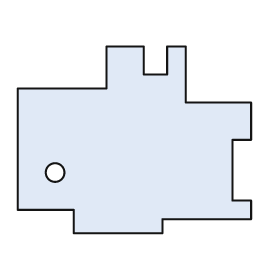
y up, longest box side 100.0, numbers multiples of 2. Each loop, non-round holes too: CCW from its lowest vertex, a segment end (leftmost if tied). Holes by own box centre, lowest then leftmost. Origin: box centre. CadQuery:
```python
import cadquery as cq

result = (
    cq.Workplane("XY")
    .moveTo(-26.0, -40.0)
    .lineTo(12.0, -40.0)
    .lineTo(12.0, -34.0)
    .lineTo(50.0, -34.0)
    .lineTo(50.0, -26.0)
    .lineTo(42.0, -26.0)
    .lineTo(42.0, 0.0)
    .lineTo(50.0, 0.0)
    .lineTo(50.0, 16.0)
    .lineTo(22.0, 16.0)
    .lineTo(22.0, 40.0)
    .lineTo(14.0, 40.0)
    .lineTo(14.0, 28.0)
    .lineTo(4.0, 28.0)
    .lineTo(4.0, 40.0)
    .lineTo(-12.0, 40.0)
    .lineTo(-12.0, 22.0)
    .lineTo(-50.0, 22.0)
    .lineTo(-50.0, -30.0)
    .lineTo(-26.0, -30.0)
    .close()
    .moveTo(-34.0, -14.0)
    .circle(4.0)
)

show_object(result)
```